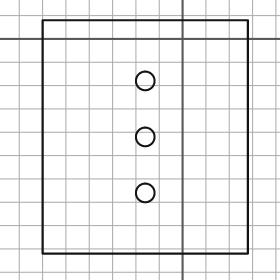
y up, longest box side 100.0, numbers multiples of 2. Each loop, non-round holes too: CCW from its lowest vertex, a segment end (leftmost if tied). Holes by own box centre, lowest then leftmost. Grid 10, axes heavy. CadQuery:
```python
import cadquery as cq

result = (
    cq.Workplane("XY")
    .moveTo(-60.0, -92.0)
    .lineTo(28.0, -92.0)
    .lineTo(28.0, 8.0)
    .lineTo(-60.0, 8.0)
    .close()
    .moveTo(-16.0, -66.0)
    .circle(4.0)
    .moveTo(-16.0, -42.0)
    .circle(4.0)
    .moveTo(-16.0, -18.0)
    .circle(4.0)
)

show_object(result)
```